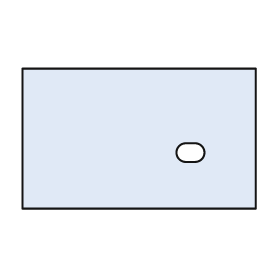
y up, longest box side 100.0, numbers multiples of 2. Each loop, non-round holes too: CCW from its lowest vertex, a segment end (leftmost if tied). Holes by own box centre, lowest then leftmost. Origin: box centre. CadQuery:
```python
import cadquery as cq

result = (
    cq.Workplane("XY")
    .moveTo(-50.0, -30.0)
    .lineTo(50.0, -30.0)
    .lineTo(50.0, 30.0)
    .lineTo(-50.0, 30.0)
    .close()
    .moveTo(20.0, -10.0)
    .lineTo(24.0, -10.0)
    .threePointArc((28.0, -6.0), (24.0, -2.0))
    .lineTo(20.0, -2.0)
    .threePointArc((16.0, -6.0), (20.0, -10.0))
    .close()
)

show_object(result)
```